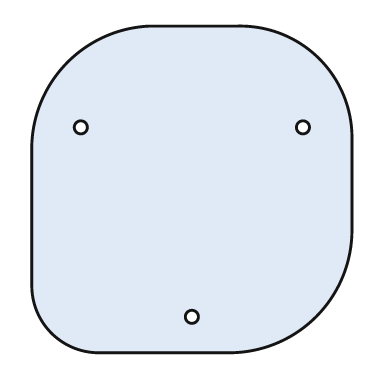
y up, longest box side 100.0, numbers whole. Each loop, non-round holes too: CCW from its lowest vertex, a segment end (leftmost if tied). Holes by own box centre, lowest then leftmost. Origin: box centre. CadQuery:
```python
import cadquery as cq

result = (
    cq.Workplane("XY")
    .moveTo(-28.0, -50.0)
    .lineTo(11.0, -50.0)
    .threePointArc((38.0, -39.0), (49.0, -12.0))
    .lineTo(49.0, 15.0)
    .threePointArc((39.0, 40.0), (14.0, 50.0))
    .lineTo(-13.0, 50.0)
    .threePointArc((-38.0, 39.0), (-49.0, 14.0))
    .lineTo(-49.0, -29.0)
    .threePointArc((-43.0, -44.0), (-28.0, -50.0))
    .close()
    .moveTo(0.0, -39.0)
    .circle(2.0)
    .moveTo(-34.0, 19.0)
    .circle(2.0)
    .moveTo(34.0, 19.0)
    .circle(2.0)
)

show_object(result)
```